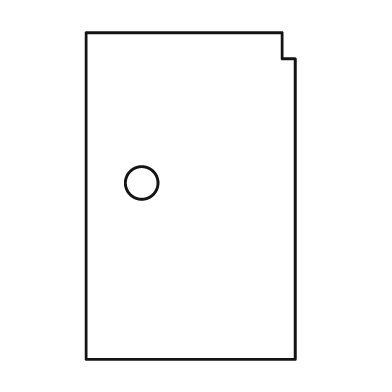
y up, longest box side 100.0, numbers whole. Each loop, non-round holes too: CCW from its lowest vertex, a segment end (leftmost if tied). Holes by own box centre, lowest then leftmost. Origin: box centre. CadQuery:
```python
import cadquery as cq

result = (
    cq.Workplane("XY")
    .moveTo(-32.0, -50.0)
    .lineTo(32.0, -50.0)
    .lineTo(32.0, 42.0)
    .lineTo(28.0, 42.0)
    .lineTo(28.0, 50.0)
    .lineTo(-32.0, 50.0)
    .close()
    .moveTo(-15.0, 4.0)
    .circle(5.0)
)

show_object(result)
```